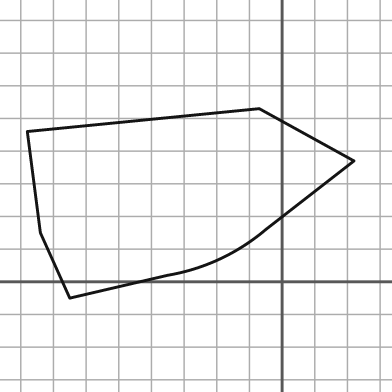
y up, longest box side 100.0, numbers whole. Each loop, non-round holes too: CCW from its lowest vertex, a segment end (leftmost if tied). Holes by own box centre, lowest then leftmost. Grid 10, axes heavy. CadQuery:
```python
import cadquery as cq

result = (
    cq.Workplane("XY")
    .moveTo(-65.0, -5.0)
    .lineTo(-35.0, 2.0)
    .threePointArc((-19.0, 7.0), (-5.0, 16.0))
    .lineTo(22.0, 37.0)
    .lineTo(-7.0, 53.0)
    .lineTo(-78.0, 46.0)
    .lineTo(-74.0, 15.0)
    .close()
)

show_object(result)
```